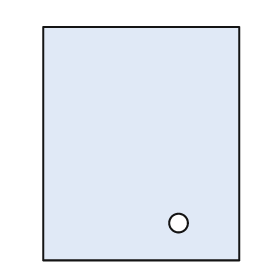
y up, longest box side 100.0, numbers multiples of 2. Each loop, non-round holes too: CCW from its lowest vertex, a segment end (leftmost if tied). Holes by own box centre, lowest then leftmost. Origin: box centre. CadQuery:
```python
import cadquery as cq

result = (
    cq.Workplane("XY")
    .moveTo(-42.0, -50.0)
    .lineTo(42.0, -50.0)
    .lineTo(42.0, 50.0)
    .lineTo(-42.0, 50.0)
    .close()
    .moveTo(16.0, -34.0)
    .circle(4.0)
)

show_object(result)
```